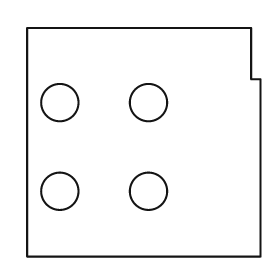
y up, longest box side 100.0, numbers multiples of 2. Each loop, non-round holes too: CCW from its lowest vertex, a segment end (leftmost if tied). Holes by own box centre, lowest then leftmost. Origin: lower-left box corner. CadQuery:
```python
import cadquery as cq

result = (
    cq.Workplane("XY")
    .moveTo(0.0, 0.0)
    .lineTo(100.0, 0.0)
    .lineTo(100.0, 76.0)
    .lineTo(96.0, 76.0)
    .lineTo(96.0, 98.0)
    .lineTo(0.0, 98.0)
    .close()
    .moveTo(14.0, 28.0)
    .circle(8.0)
    .moveTo(52.0, 28.0)
    .circle(8.0)
    .moveTo(14.0, 66.0)
    .circle(8.0)
    .moveTo(52.0, 66.0)
    .circle(8.0)
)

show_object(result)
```